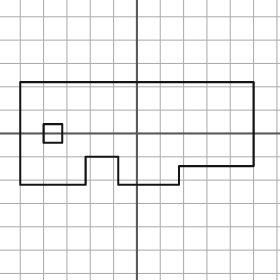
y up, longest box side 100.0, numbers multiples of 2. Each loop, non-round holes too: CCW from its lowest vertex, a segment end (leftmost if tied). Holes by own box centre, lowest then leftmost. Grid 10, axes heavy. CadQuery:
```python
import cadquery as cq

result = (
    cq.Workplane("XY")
    .moveTo(-50.0, -22.0)
    .lineTo(-22.0, -22.0)
    .lineTo(-22.0, -10.0)
    .lineTo(-8.0, -10.0)
    .lineTo(-8.0, -22.0)
    .lineTo(18.0, -22.0)
    .lineTo(18.0, -14.0)
    .lineTo(50.0, -14.0)
    .lineTo(50.0, 22.0)
    .lineTo(-50.0, 22.0)
    .close()
    .moveTo(-40.0, -4.0)
    .lineTo(-32.0, -4.0)
    .lineTo(-32.0, 4.0)
    .lineTo(-40.0, 4.0)
    .close()
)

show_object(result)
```